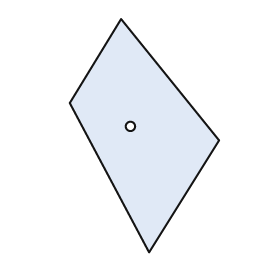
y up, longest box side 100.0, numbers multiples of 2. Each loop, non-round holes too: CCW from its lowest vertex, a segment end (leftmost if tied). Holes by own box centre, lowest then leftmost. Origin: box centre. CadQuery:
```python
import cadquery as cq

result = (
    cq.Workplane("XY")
    .moveTo(2.0, -50.0)
    .lineTo(32.0, -2.0)
    .lineTo(-10.0, 50.0)
    .lineTo(-32.0, 14.0)
    .close()
    .moveTo(-6.0, 4.0)
    .circle(2.0)
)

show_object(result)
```